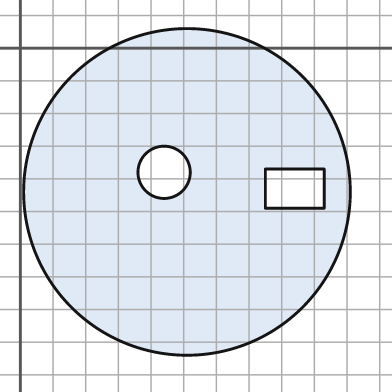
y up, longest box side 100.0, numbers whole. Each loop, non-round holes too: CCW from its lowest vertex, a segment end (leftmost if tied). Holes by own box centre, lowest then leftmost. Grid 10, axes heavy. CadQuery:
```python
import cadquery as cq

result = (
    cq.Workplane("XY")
    .moveTo(51.0, -44.0)
    .circle(50.0)
    .moveTo(75.0, -49.0)
    .lineTo(93.0, -49.0)
    .lineTo(93.0, -37.0)
    .lineTo(75.0, -37.0)
    .close()
    .moveTo(44.0, -38.0)
    .circle(8.0)
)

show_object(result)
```